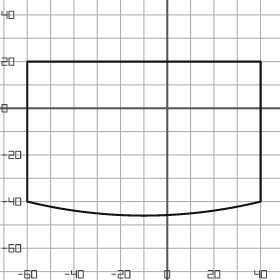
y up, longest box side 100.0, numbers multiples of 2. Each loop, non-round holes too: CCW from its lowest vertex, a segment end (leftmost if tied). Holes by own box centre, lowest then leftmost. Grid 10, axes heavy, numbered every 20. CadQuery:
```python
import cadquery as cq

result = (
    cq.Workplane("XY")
    .moveTo(-60.0, -40.0)
    .threePointArc((-10.0, -46.0), (40.0, -40.0))
    .lineTo(40.0, 20.0)
    .lineTo(-60.0, 20.0)
    .close()
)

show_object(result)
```